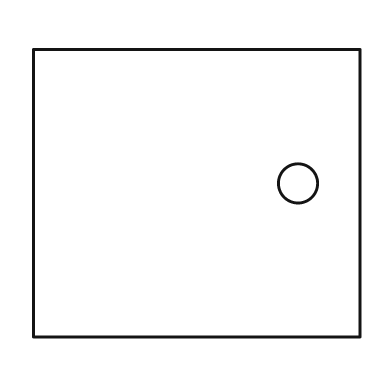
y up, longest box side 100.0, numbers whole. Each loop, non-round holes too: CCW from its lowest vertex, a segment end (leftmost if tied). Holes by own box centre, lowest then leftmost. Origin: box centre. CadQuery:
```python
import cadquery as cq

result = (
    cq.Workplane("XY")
    .moveTo(-50.0, -44.0)
    .lineTo(50.0, -44.0)
    .lineTo(50.0, 44.0)
    .lineTo(-50.0, 44.0)
    .close()
    .moveTo(31.0, 3.0)
    .circle(6.0)
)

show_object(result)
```